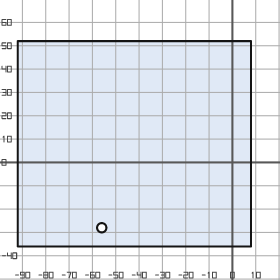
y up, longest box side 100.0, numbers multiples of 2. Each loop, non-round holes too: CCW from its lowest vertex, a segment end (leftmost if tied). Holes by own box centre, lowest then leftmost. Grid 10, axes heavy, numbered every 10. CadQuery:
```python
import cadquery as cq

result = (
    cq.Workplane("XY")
    .moveTo(-92.0, -36.0)
    .lineTo(8.0, -36.0)
    .lineTo(8.0, 52.0)
    .lineTo(-92.0, 52.0)
    .close()
    .moveTo(-56.0, -28.0)
    .circle(2.0)
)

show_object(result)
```